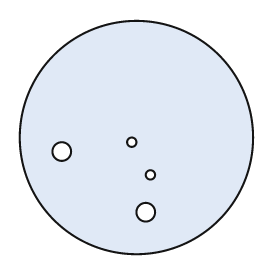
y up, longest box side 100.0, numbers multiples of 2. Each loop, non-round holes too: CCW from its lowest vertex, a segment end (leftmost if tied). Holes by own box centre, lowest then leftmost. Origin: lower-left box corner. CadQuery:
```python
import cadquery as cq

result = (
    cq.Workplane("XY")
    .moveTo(50.0, 50.0)
    .circle(50.0)
    .moveTo(54.0, 18.0)
    .circle(4.0)
    .moveTo(56.0, 34.0)
    .circle(2.0)
    .moveTo(18.0, 44.0)
    .circle(4.0)
    .moveTo(48.0, 48.0)
    .circle(2.0)
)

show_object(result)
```